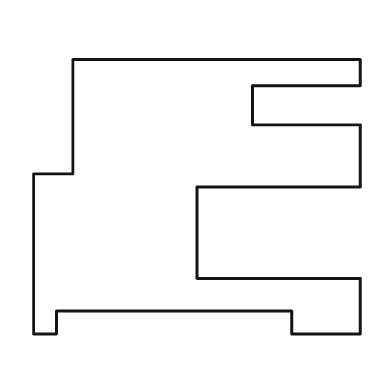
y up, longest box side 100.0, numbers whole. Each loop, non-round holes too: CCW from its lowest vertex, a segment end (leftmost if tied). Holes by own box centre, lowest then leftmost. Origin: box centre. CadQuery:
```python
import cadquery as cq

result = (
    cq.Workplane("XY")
    .moveTo(-50.0, -42.0)
    .lineTo(-43.0, -42.0)
    .lineTo(-43.0, -35.0)
    .lineTo(29.0, -35.0)
    .lineTo(29.0, -42.0)
    .lineTo(50.0, -42.0)
    .lineTo(50.0, -25.0)
    .lineTo(0.0, -25.0)
    .lineTo(0.0, 3.0)
    .lineTo(50.0, 3.0)
    .lineTo(50.0, 22.0)
    .lineTo(17.0, 22.0)
    .lineTo(17.0, 34.0)
    .lineTo(50.0, 34.0)
    .lineTo(50.0, 42.0)
    .lineTo(-38.0, 42.0)
    .lineTo(-38.0, 7.0)
    .lineTo(-50.0, 7.0)
    .close()
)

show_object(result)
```